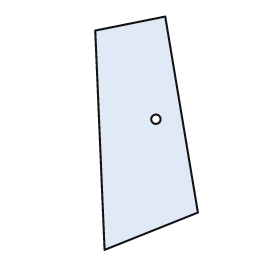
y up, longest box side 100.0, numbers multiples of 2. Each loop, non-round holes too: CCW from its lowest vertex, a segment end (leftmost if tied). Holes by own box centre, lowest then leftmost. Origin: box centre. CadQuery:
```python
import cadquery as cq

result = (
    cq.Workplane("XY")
    .moveTo(-18.0, -50.0)
    .lineTo(22.0, -34.0)
    .lineTo(8.0, 50.0)
    .lineTo(-22.0, 44.0)
    .close()
    .moveTo(4.0, 6.0)
    .circle(2.0)
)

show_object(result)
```